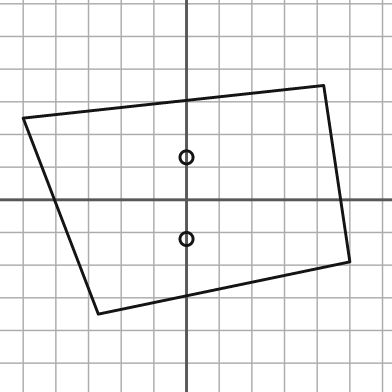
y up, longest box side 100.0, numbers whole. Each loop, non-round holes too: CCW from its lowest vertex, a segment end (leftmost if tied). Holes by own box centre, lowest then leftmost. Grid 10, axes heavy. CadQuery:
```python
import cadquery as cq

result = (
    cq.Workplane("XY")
    .moveTo(-27.0, -35.0)
    .lineTo(50.0, -19.0)
    .lineTo(42.0, 35.0)
    .lineTo(-50.0, 25.0)
    .close()
    .moveTo(0.0, -12.0)
    .circle(2.0)
    .moveTo(0.0, 13.0)
    .circle(2.0)
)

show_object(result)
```